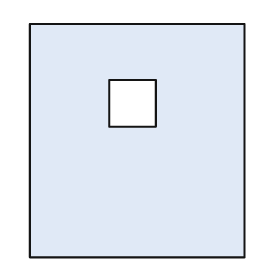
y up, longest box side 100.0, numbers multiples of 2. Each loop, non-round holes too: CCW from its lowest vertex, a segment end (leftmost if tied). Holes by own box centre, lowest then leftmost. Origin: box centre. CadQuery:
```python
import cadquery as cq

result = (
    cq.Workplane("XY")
    .moveTo(-46.0, -50.0)
    .lineTo(46.0, -50.0)
    .lineTo(46.0, 50.0)
    .lineTo(-46.0, 50.0)
    .close()
    .moveTo(-12.0, 6.0)
    .lineTo(8.0, 6.0)
    .lineTo(8.0, 26.0)
    .lineTo(-12.0, 26.0)
    .close()
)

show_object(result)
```